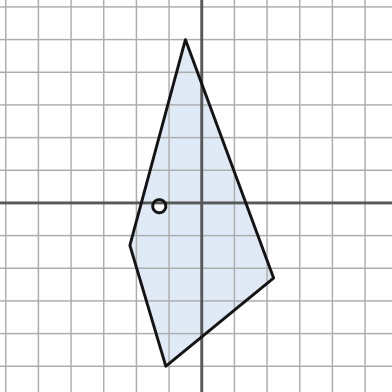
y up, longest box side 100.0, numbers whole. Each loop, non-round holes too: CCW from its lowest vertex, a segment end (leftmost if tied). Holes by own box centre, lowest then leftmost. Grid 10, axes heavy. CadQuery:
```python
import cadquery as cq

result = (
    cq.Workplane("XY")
    .moveTo(-11.0, -50.0)
    .lineTo(22.0, -23.0)
    .lineTo(-5.0, 50.0)
    .lineTo(-22.0, -13.0)
    .close()
    .moveTo(-13.0, -1.0)
    .circle(2.0)
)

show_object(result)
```